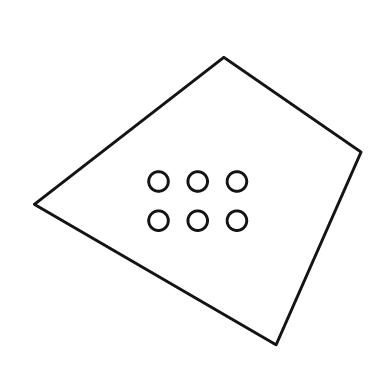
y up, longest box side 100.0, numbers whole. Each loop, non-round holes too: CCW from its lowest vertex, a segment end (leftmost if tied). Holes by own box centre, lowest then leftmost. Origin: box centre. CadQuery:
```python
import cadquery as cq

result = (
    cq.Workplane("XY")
    .moveTo(24.0, -44.0)
    .lineTo(50.0, 15.0)
    .lineTo(8.0, 44.0)
    .lineTo(-50.0, -1.0)
    .close()
    .moveTo(-12.0, -6.0)
    .circle(3.0)
    .moveTo(0.0, -6.0)
    .circle(3.0)
    .moveTo(12.0, -6.0)
    .circle(3.0)
    .moveTo(-12.0, 6.0)
    .circle(3.0)
    .moveTo(0.0, 6.0)
    .circle(3.0)
    .moveTo(12.0, 6.0)
    .circle(3.0)
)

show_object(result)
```